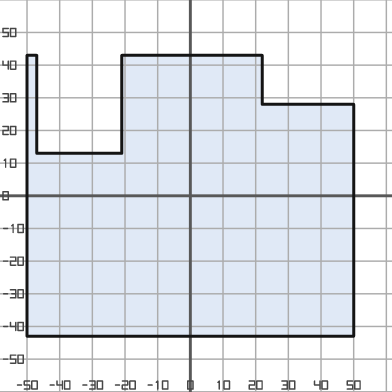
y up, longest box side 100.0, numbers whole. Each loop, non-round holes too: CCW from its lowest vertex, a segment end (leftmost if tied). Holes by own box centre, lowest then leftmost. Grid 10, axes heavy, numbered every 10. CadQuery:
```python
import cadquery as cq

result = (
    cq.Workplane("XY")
    .moveTo(-50.0, -43.0)
    .lineTo(50.0, -43.0)
    .lineTo(50.0, 28.0)
    .lineTo(22.0, 28.0)
    .lineTo(22.0, 43.0)
    .lineTo(-21.0, 43.0)
    .lineTo(-21.0, 13.0)
    .lineTo(-47.0, 13.0)
    .lineTo(-47.0, 43.0)
    .lineTo(-50.0, 43.0)
    .close()
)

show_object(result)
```